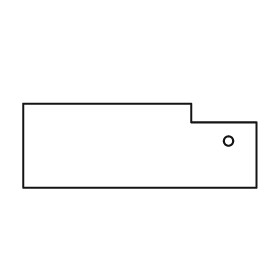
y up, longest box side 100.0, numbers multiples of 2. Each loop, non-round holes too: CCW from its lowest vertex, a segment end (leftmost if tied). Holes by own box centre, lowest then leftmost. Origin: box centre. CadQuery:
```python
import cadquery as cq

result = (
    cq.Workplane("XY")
    .moveTo(-50.0, -18.0)
    .lineTo(50.0, -18.0)
    .lineTo(50.0, 10.0)
    .lineTo(22.0, 10.0)
    .lineTo(22.0, 18.0)
    .lineTo(-50.0, 18.0)
    .close()
    .moveTo(38.0, 2.0)
    .circle(2.0)
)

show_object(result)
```